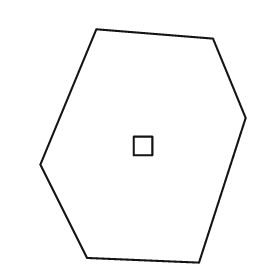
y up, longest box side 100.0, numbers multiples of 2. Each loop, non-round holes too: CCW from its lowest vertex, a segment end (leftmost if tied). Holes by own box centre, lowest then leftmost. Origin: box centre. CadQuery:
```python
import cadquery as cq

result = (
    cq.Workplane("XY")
    .moveTo(24.0, -50.0)
    .lineTo(44.0, 12.0)
    .lineTo(30.0, 46.0)
    .lineTo(-20.0, 50.0)
    .lineTo(-44.0, -8.0)
    .lineTo(-24.0, -48.0)
    .close()
    .moveTo(-4.0, -4.0)
    .lineTo(4.0, -4.0)
    .lineTo(4.0, 4.0)
    .lineTo(-4.0, 4.0)
    .close()
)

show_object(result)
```